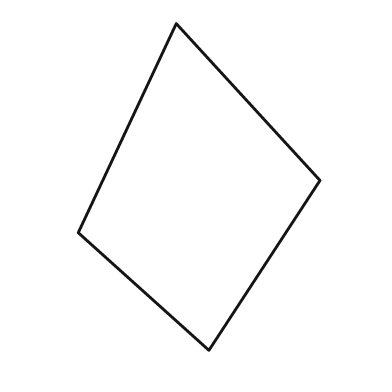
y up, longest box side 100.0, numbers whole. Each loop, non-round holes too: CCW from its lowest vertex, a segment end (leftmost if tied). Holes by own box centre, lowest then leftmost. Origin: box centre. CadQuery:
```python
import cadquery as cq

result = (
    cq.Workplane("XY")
    .moveTo(3.0, -50.0)
    .lineTo(37.0, 2.0)
    .lineTo(-7.0, 50.0)
    .lineTo(-37.0, -14.0)
    .close()
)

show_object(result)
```